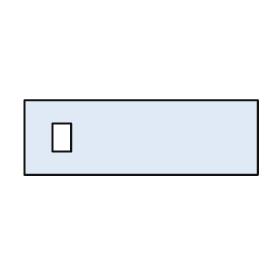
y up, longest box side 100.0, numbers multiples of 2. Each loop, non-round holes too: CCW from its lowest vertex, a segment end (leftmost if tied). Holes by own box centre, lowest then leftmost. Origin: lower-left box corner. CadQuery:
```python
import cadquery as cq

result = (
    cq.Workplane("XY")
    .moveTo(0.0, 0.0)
    .lineTo(100.0, 0.0)
    .lineTo(100.0, 32.0)
    .lineTo(0.0, 32.0)
    .close()
    .moveTo(12.0, 10.0)
    .lineTo(20.0, 10.0)
    .lineTo(20.0, 22.0)
    .lineTo(12.0, 22.0)
    .close()
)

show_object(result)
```